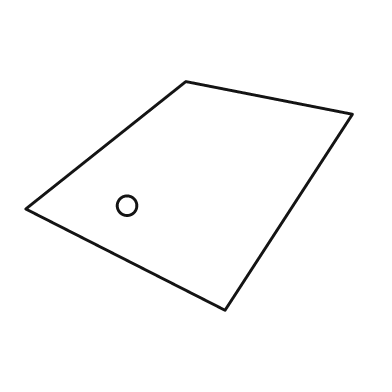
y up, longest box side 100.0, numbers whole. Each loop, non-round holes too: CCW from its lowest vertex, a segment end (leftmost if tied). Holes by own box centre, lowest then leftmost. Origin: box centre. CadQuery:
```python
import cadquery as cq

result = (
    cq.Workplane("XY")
    .moveTo(11.0, -35.0)
    .lineTo(50.0, 25.0)
    .lineTo(-1.0, 35.0)
    .lineTo(-50.0, -4.0)
    .close()
    .moveTo(-19.0, -3.0)
    .circle(3.0)
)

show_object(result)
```